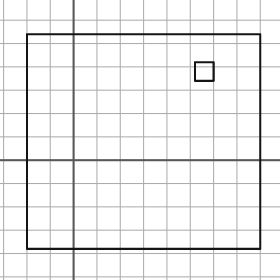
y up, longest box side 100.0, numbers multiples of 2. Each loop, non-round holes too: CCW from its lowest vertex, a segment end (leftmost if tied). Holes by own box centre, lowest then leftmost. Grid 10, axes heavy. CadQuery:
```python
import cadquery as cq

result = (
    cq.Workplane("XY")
    .moveTo(-20.0, -38.0)
    .lineTo(80.0, -38.0)
    .lineTo(80.0, 54.0)
    .lineTo(-20.0, 54.0)
    .close()
    .moveTo(52.0, 34.0)
    .lineTo(60.0, 34.0)
    .lineTo(60.0, 42.0)
    .lineTo(52.0, 42.0)
    .close()
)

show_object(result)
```